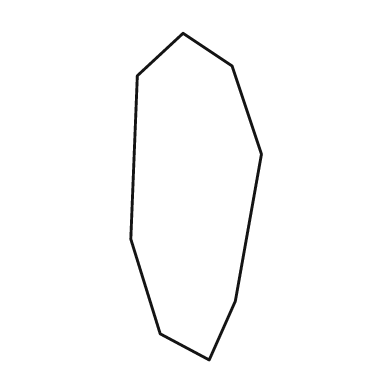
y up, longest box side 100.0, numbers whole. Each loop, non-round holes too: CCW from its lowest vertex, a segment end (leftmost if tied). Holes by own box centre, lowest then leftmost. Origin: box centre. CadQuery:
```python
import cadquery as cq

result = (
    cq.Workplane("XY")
    .moveTo(4.0, -50.0)
    .lineTo(12.0, -32.0)
    .lineTo(20.0, 13.0)
    .lineTo(11.0, 40.0)
    .lineTo(-4.0, 50.0)
    .lineTo(-18.0, 37.0)
    .lineTo(-20.0, -13.0)
    .lineTo(-11.0, -42.0)
    .close()
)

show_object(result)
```